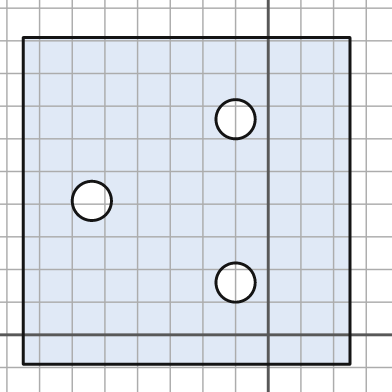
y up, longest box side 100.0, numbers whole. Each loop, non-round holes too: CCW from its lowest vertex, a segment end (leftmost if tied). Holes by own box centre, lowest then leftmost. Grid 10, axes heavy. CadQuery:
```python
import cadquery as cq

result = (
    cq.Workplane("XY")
    .moveTo(-75.0, -9.0)
    .lineTo(25.0, -9.0)
    .lineTo(25.0, 91.0)
    .lineTo(-75.0, 91.0)
    .close()
    .moveTo(-10.0, 16.0)
    .circle(6.0)
    .moveTo(-54.0, 41.0)
    .circle(6.0)
    .moveTo(-10.0, 66.0)
    .circle(6.0)
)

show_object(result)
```